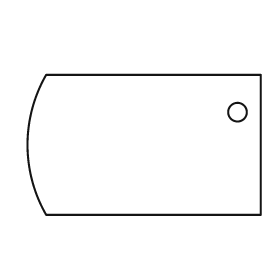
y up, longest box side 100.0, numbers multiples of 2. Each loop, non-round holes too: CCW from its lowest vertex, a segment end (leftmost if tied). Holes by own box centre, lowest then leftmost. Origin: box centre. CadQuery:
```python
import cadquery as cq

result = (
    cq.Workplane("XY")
    .moveTo(-42.0, -30.0)
    .lineTo(50.0, -30.0)
    .lineTo(50.0, 30.0)
    .lineTo(-42.0, 30.0)
    .threePointArc((-50.0, 0.0), (-42.0, -30.0))
    .close()
    .moveTo(40.0, 14.0)
    .circle(4.0)
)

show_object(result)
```